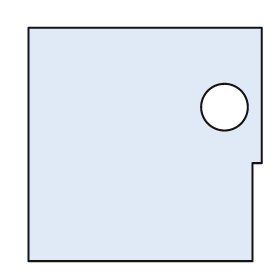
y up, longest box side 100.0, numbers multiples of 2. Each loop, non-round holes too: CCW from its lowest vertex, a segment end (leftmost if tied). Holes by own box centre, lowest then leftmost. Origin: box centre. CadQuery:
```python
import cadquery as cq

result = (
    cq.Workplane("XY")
    .moveTo(-50.0, -50.0)
    .lineTo(46.0, -50.0)
    .lineTo(46.0, -8.0)
    .lineTo(50.0, -8.0)
    .lineTo(50.0, 50.0)
    .lineTo(-50.0, 50.0)
    .close()
    .moveTo(34.0, 16.0)
    .circle(10.0)
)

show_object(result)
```